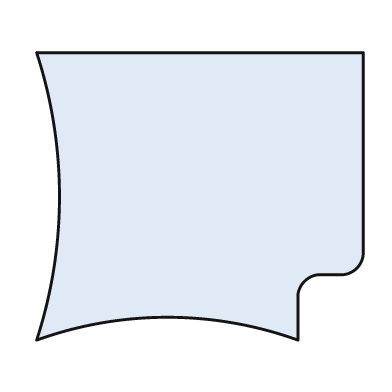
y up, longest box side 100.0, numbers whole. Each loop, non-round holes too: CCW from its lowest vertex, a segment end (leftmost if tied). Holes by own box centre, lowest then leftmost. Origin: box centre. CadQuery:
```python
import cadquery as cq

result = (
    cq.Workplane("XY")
    .moveTo(-50.0, -44.0)
    .threePointArc((-10.0, -37.0), (30.0, -44.0))
    .lineTo(30.0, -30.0)
    .threePointArc((32.0, -26.0), (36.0, -24.0))
    .lineTo(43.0, -24.0)
    .threePointArc((48.0, -22.0), (50.0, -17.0))
    .lineTo(50.0, 44.0)
    .lineTo(-50.0, 44.0)
    .threePointArc((-43.0, 0.0), (-50.0, -44.0))
    .close()
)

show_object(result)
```